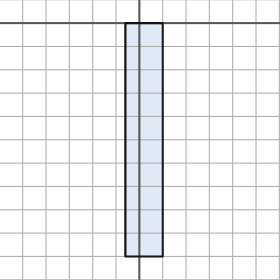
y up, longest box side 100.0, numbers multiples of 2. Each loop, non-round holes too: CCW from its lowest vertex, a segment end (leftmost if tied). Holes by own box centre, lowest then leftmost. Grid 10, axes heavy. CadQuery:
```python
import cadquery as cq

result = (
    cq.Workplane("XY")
    .moveTo(-6.0, -100.0)
    .lineTo(10.0, -100.0)
    .lineTo(10.0, 0.0)
    .lineTo(-6.0, 0.0)
    .close()
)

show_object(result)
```